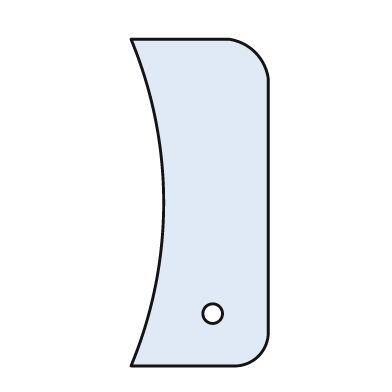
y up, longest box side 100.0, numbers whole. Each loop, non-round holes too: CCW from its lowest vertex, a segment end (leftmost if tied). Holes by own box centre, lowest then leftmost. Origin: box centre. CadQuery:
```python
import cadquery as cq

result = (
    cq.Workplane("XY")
    .moveTo(-21.0, -50.0)
    .lineTo(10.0, -50.0)
    .threePointArc((18.0, -47.0), (21.0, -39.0))
    .lineTo(21.0, 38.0)
    .threePointArc((17.0, 46.0), (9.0, 50.0))
    .lineTo(-21.0, 50.0)
    .threePointArc((-11.0, 0.0), (-21.0, -50.0))
    .close()
    .moveTo(4.0, -34.0)
    .circle(3.0)
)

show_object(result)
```